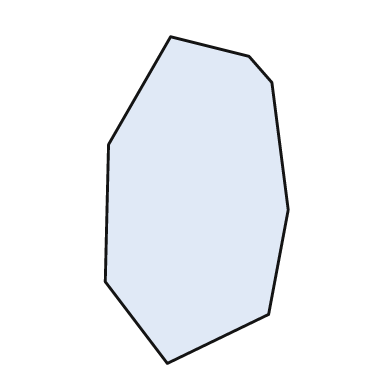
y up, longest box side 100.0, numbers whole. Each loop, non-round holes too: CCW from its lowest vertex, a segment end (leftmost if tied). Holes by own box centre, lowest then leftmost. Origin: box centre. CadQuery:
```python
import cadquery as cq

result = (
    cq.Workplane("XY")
    .moveTo(-9.0, -50.0)
    .lineTo(22.0, -35.0)
    .lineTo(28.0, -3.0)
    .lineTo(23.0, 36.0)
    .lineTo(16.0, 44.0)
    .lineTo(-8.0, 50.0)
    .lineTo(-27.0, 17.0)
    .lineTo(-28.0, -25.0)
    .close()
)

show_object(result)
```